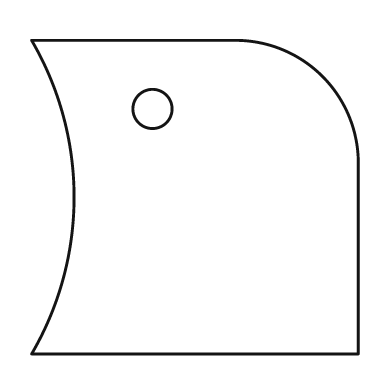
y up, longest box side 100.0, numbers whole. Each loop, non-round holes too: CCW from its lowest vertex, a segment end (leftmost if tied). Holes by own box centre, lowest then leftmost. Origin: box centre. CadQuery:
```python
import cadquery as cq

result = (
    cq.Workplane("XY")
    .moveTo(-50.0, -48.0)
    .lineTo(50.0, -48.0)
    .lineTo(50.0, 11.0)
    .threePointArc((39.0, 37.0), (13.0, 48.0))
    .lineTo(-50.0, 48.0)
    .threePointArc((-37.0, 0.0), (-50.0, -48.0))
    .close()
    .moveTo(-13.0, 27.0)
    .circle(6.0)
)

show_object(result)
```